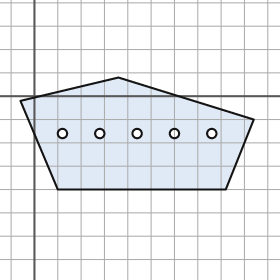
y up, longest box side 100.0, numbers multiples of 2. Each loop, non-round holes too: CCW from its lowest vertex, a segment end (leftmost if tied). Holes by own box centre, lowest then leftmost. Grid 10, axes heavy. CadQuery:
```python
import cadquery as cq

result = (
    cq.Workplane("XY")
    .moveTo(10.0, -40.0)
    .lineTo(82.0, -40.0)
    .lineTo(94.0, -10.0)
    .lineTo(36.0, 8.0)
    .lineTo(-6.0, -2.0)
    .close()
    .moveTo(12.0, -16.0)
    .circle(2.0)
    .moveTo(28.0, -16.0)
    .circle(2.0)
    .moveTo(44.0, -16.0)
    .circle(2.0)
    .moveTo(60.0, -16.0)
    .circle(2.0)
    .moveTo(76.0, -16.0)
    .circle(2.0)
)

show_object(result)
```